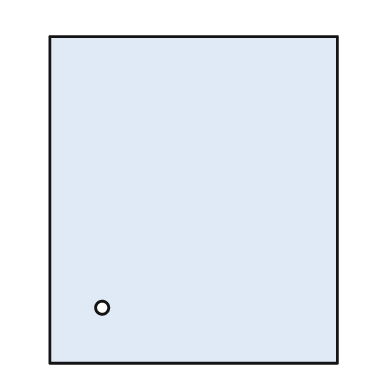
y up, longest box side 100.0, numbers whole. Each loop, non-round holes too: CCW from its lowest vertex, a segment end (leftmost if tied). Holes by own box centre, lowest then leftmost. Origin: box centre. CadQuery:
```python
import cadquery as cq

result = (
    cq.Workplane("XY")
    .moveTo(-44.0, -50.0)
    .lineTo(44.0, -50.0)
    .lineTo(44.0, 50.0)
    .lineTo(-44.0, 50.0)
    .close()
    .moveTo(-28.0, -33.0)
    .circle(2.0)
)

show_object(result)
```